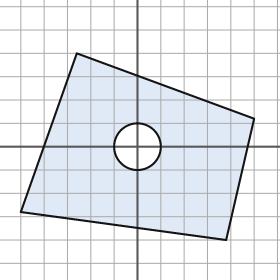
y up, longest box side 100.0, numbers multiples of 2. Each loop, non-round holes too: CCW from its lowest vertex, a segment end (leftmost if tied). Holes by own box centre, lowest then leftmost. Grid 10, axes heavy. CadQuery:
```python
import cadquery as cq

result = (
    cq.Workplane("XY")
    .moveTo(38.0, -40.0)
    .lineTo(50.0, 12.0)
    .lineTo(-26.0, 40.0)
    .lineTo(-50.0, -28.0)
    .close()
    .moveTo(0.0, 0.0)
    .circle(10.0)
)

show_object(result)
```